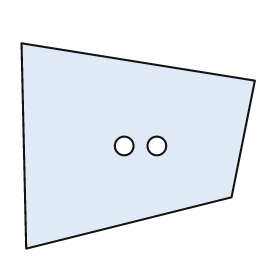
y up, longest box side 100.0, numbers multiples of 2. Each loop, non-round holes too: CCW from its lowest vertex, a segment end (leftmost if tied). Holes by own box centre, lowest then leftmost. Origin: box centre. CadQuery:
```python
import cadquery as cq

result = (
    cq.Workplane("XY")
    .moveTo(-48.0, -44.0)
    .lineTo(40.0, -22.0)
    .lineTo(50.0, 28.0)
    .lineTo(-50.0, 44.0)
    .close()
    .moveTo(-6.0, 0.0)
    .circle(4.0)
    .moveTo(8.0, 0.0)
    .circle(4.0)
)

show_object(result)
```